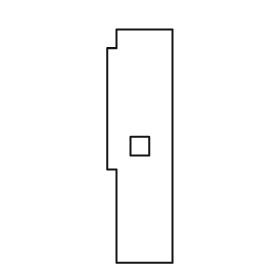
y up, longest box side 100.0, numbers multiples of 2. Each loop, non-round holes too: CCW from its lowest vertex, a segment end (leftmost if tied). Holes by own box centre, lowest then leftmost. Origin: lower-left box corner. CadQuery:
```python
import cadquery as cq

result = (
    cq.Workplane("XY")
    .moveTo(4.0, 0.0)
    .lineTo(28.0, 0.0)
    .lineTo(28.0, 100.0)
    .lineTo(4.0, 100.0)
    .lineTo(4.0, 92.0)
    .lineTo(0.0, 92.0)
    .lineTo(0.0, 40.0)
    .lineTo(4.0, 40.0)
    .close()
    .moveTo(10.0, 46.0)
    .lineTo(18.0, 46.0)
    .lineTo(18.0, 54.0)
    .lineTo(10.0, 54.0)
    .close()
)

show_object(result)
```